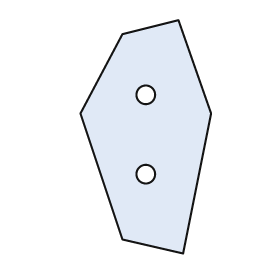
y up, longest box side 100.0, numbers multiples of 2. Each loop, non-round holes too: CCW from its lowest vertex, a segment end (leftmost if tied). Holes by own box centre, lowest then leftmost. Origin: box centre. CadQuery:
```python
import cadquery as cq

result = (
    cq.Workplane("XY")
    .moveTo(16.0, -50.0)
    .lineTo(28.0, 10.0)
    .lineTo(14.0, 50.0)
    .lineTo(-10.0, 44.0)
    .lineTo(-28.0, 10.0)
    .lineTo(-10.0, -44.0)
    .close()
    .moveTo(0.0, -16.0)
    .circle(4.0)
    .moveTo(0.0, 18.0)
    .circle(4.0)
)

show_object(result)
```